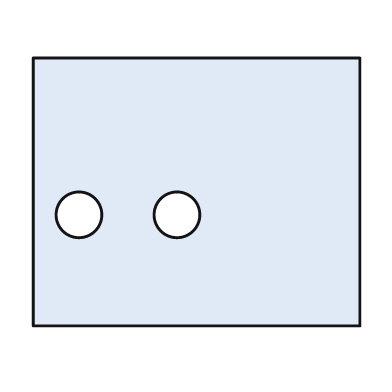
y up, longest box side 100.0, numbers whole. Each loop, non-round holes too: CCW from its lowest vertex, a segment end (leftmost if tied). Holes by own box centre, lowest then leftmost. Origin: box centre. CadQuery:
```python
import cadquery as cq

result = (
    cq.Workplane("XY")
    .moveTo(-50.0, -41.0)
    .lineTo(50.0, -41.0)
    .lineTo(50.0, 41.0)
    .lineTo(-50.0, 41.0)
    .close()
    .moveTo(-36.0, -7.0)
    .circle(7.0)
    .moveTo(-6.0, -7.0)
    .circle(7.0)
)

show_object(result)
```